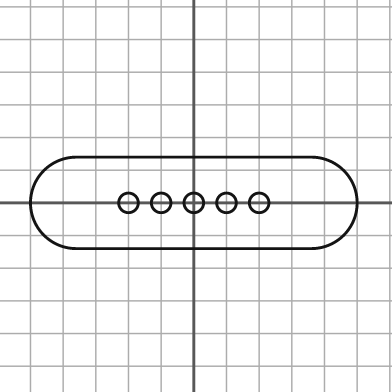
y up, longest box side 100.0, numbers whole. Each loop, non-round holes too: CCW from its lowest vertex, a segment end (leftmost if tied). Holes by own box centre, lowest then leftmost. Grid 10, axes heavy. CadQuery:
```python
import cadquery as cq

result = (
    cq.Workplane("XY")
    .moveTo(-36.0, -14.0)
    .lineTo(36.0, -14.0)
    .threePointArc((50.0, 0.0), (36.0, 14.0))
    .lineTo(-36.0, 14.0)
    .threePointArc((-50.0, 0.0), (-36.0, -14.0))
    .close()
    .moveTo(-20.0, 0.0)
    .circle(3.0)
    .moveTo(-10.0, 0.0)
    .circle(3.0)
    .moveTo(0.0, 0.0)
    .circle(3.0)
    .moveTo(10.0, 0.0)
    .circle(3.0)
    .moveTo(20.0, 0.0)
    .circle(3.0)
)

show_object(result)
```